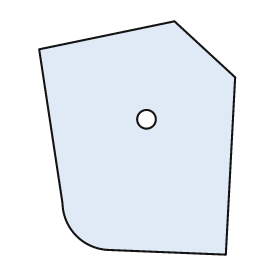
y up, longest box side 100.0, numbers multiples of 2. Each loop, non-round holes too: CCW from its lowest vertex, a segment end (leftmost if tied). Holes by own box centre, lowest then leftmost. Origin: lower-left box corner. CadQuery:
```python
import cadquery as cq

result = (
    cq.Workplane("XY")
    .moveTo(80.0, 0.0)
    .lineTo(84.0, 76.0)
    .lineTo(58.0, 100.0)
    .lineTo(0.0, 88.0)
    .lineTo(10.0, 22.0)
    .threePointArc((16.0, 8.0), (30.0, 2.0))
    .close()
    .moveTo(46.0, 58.0)
    .circle(4.0)
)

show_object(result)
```